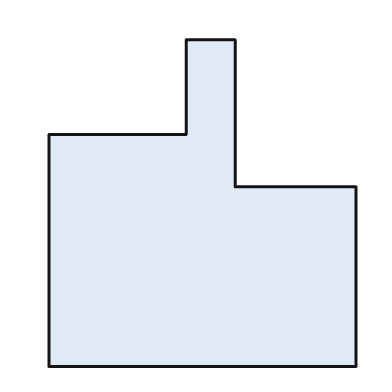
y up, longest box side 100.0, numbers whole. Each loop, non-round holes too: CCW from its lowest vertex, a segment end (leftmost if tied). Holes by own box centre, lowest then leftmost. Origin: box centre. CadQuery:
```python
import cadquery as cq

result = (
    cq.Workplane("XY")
    .moveTo(-47.0, -50.0)
    .lineTo(47.0, -50.0)
    .lineTo(47.0, 5.0)
    .lineTo(10.0, 5.0)
    .lineTo(10.0, 50.0)
    .lineTo(-5.0, 50.0)
    .lineTo(-5.0, 21.0)
    .lineTo(-47.0, 21.0)
    .close()
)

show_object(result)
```